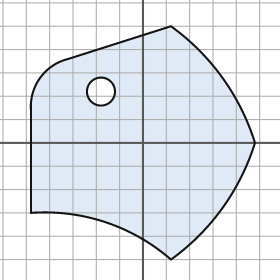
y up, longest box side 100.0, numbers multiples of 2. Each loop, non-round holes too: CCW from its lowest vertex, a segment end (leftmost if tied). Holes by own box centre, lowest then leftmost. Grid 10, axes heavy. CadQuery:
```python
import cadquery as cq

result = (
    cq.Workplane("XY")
    .moveTo(12.0, -50.0)
    .threePointArc((34.0, -28.0), (48.0, 0.0))
    .threePointArc((34.0, 28.0), (12.0, 50.0))
    .lineTo(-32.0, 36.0)
    .threePointArc((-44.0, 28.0), (-48.0, 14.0))
    .lineTo(-48.0, -30.0)
    .threePointArc((-16.0, -34.0), (12.0, -50.0))
    .close()
    .moveTo(-18.0, 22.0)
    .circle(6.0)
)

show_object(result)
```